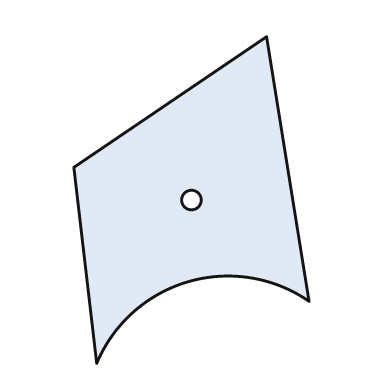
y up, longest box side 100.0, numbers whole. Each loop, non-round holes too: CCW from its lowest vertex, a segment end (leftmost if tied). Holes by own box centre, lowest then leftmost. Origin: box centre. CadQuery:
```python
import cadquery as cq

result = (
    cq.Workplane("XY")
    .moveTo(-29.0, -50.0)
    .threePointArc((-1.0, -25.0), (36.0, -31.0))
    .lineTo(23.0, 50.0)
    .lineTo(-36.0, 10.0)
    .close()
    .moveTo(0.0, 0.0)
    .circle(3.0)
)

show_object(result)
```